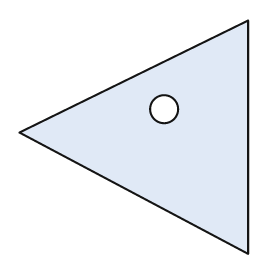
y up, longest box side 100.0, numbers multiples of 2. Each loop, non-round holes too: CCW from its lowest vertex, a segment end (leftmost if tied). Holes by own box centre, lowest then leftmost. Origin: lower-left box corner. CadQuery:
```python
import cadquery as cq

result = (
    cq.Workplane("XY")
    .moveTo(98.0, 0.0)
    .lineTo(98.0, 100.0)
    .lineTo(0.0, 52.0)
    .close()
    .moveTo(62.0, 62.0)
    .circle(6.0)
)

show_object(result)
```